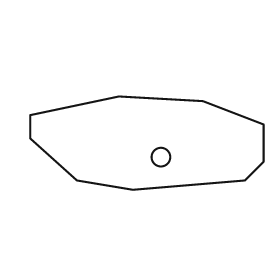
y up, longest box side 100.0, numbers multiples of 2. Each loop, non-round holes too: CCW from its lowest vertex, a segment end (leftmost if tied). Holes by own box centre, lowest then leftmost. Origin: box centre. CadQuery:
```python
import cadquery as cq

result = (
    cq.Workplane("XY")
    .moveTo(-6.0, -20.0)
    .lineTo(42.0, -16.0)
    .lineTo(50.0, -8.0)
    .lineTo(50.0, 8.0)
    .lineTo(24.0, 18.0)
    .lineTo(-12.0, 20.0)
    .lineTo(-50.0, 12.0)
    .lineTo(-50.0, 2.0)
    .lineTo(-30.0, -16.0)
    .close()
    .moveTo(6.0, -6.0)
    .circle(4.0)
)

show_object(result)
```